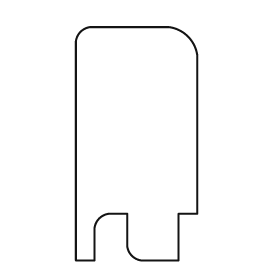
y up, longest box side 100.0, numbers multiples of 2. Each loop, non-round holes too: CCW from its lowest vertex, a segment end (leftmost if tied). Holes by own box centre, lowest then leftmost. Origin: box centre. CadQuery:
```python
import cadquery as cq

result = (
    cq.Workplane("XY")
    .moveTo(-26.0, -50.0)
    .lineTo(-18.0, -50.0)
    .lineTo(-18.0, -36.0)
    .threePointArc((-16.0, -32.0), (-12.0, -30.0))
    .lineTo(-4.0, -30.0)
    .lineTo(-4.0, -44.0)
    .threePointArc((-2.0, -48.0), (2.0, -50.0))
    .lineTo(18.0, -50.0)
    .lineTo(18.0, -30.0)
    .lineTo(26.0, -30.0)
    .lineTo(26.0, 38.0)
    .threePointArc((22.0, 46.0), (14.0, 50.0))
    .lineTo(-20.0, 50.0)
    .threePointArc((-24.0, 48.0), (-26.0, 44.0))
    .close()
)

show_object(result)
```